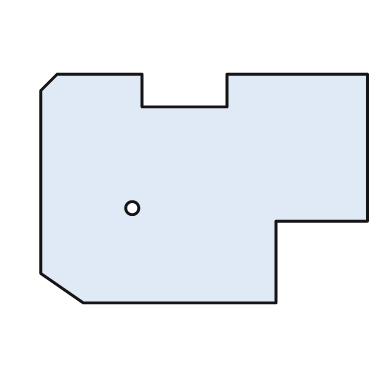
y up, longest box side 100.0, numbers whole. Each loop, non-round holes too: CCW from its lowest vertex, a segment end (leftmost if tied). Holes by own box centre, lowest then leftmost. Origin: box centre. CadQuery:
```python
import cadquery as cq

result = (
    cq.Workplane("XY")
    .moveTo(-37.0, -35.0)
    .lineTo(22.0, -35.0)
    .lineTo(22.0, -10.0)
    .lineTo(50.0, -10.0)
    .lineTo(50.0, 35.0)
    .lineTo(7.0, 35.0)
    .lineTo(7.0, 25.0)
    .lineTo(-19.0, 25.0)
    .lineTo(-19.0, 35.0)
    .lineTo(-45.0, 35.0)
    .lineTo(-50.0, 30.0)
    .lineTo(-50.0, -26.0)
    .close()
    .moveTo(-22.0, -6.0)
    .circle(2.0)
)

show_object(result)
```